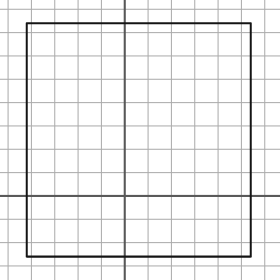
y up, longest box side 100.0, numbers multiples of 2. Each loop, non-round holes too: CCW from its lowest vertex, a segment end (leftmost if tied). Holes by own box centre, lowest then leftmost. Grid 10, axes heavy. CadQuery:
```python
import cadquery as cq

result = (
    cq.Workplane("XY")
    .moveTo(-42.0, -26.0)
    .lineTo(54.0, -26.0)
    .lineTo(54.0, 74.0)
    .lineTo(-42.0, 74.0)
    .close()
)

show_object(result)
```